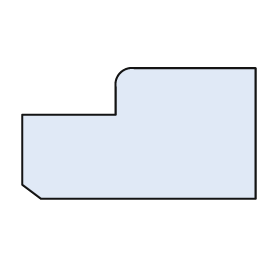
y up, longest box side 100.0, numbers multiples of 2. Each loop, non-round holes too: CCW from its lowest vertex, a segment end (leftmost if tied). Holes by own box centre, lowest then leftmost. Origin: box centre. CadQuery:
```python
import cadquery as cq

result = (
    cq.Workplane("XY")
    .moveTo(-42.0, -28.0)
    .lineTo(50.0, -28.0)
    .lineTo(50.0, 28.0)
    .lineTo(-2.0, 28.0)
    .threePointArc((-8.0, 26.0), (-10.0, 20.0))
    .lineTo(-10.0, 8.0)
    .lineTo(-50.0, 8.0)
    .lineTo(-50.0, -22.0)
    .close()
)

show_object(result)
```